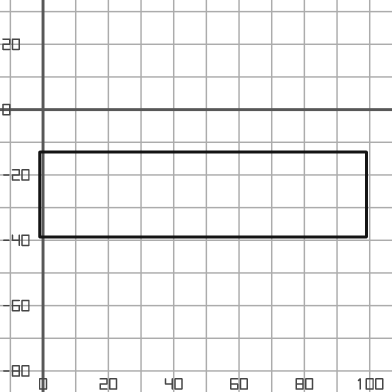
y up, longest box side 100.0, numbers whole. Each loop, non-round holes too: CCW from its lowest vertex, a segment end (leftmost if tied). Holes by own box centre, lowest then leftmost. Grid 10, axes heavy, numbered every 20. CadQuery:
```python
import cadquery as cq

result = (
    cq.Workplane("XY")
    .moveTo(-1.0, -39.0)
    .lineTo(99.0, -39.0)
    .lineTo(99.0, -13.0)
    .lineTo(-1.0, -13.0)
    .close()
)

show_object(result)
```